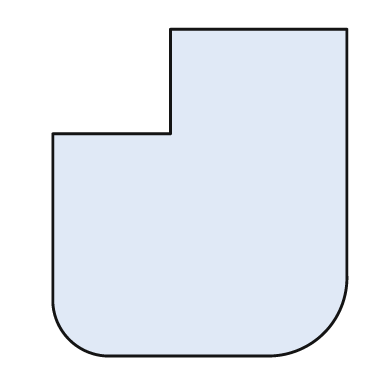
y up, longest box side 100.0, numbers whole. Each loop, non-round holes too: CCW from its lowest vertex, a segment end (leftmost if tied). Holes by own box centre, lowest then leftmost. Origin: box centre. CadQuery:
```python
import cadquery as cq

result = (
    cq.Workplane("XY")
    .moveTo(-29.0, -50.0)
    .lineTo(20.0, -50.0)
    .threePointArc((38.0, -43.0), (45.0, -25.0))
    .lineTo(45.0, 50.0)
    .lineTo(-9.0, 50.0)
    .lineTo(-9.0, 18.0)
    .lineTo(-45.0, 18.0)
    .lineTo(-45.0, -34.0)
    .threePointArc((-40.0, -45.0), (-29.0, -50.0))
    .close()
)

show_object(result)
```